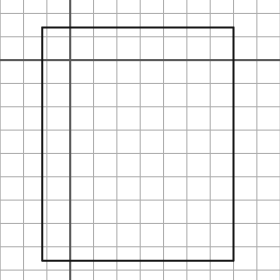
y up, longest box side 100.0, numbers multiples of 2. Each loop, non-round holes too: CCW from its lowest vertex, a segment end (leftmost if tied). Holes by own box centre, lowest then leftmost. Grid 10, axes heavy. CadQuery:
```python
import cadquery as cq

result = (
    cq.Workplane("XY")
    .moveTo(-12.0, -86.0)
    .lineTo(70.0, -86.0)
    .lineTo(70.0, 14.0)
    .lineTo(-12.0, 14.0)
    .close()
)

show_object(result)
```